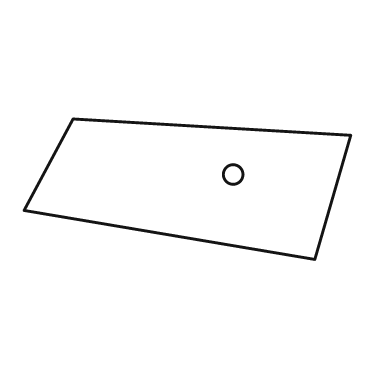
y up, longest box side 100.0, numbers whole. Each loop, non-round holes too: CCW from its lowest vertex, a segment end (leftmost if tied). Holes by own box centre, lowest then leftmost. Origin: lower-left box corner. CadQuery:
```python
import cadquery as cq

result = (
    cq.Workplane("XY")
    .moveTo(89.0, 0.0)
    .lineTo(100.0, 38.0)
    .lineTo(15.0, 43.0)
    .lineTo(0.0, 15.0)
    .close()
    .moveTo(64.0, 26.0)
    .circle(3.0)
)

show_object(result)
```